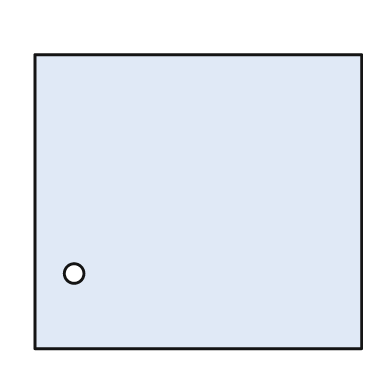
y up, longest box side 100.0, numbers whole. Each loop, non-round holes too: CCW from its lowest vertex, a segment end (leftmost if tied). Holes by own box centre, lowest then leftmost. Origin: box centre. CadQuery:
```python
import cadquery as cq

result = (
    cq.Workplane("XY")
    .moveTo(-50.0, -45.0)
    .lineTo(50.0, -45.0)
    .lineTo(50.0, 45.0)
    .lineTo(-50.0, 45.0)
    .close()
    .moveTo(-38.0, -22.0)
    .circle(3.0)
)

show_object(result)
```